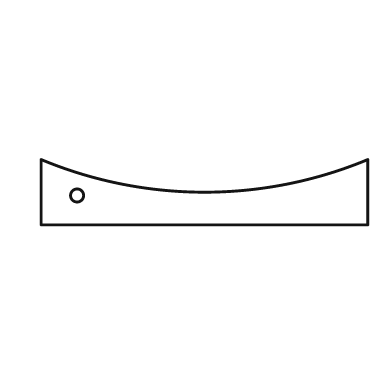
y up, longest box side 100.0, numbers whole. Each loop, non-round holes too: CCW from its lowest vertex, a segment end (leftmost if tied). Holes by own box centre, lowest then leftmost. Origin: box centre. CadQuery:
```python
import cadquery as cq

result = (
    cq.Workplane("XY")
    .moveTo(-50.0, -10.0)
    .lineTo(50.0, -10.0)
    .lineTo(50.0, 10.0)
    .threePointArc((0.0, 0.0), (-50.0, 10.0))
    .close()
    .moveTo(-39.0, -1.0)
    .circle(2.0)
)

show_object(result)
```